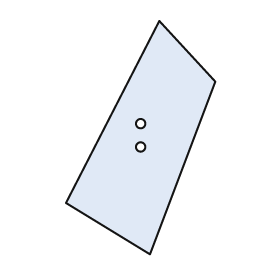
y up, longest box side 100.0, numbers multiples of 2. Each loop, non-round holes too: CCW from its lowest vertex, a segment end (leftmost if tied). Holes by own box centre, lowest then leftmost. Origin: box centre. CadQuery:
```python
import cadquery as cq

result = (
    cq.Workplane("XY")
    .moveTo(4.0, -50.0)
    .lineTo(32.0, 24.0)
    .lineTo(8.0, 50.0)
    .lineTo(-32.0, -28.0)
    .close()
    .moveTo(0.0, -4.0)
    .circle(2.0)
    .moveTo(0.0, 6.0)
    .circle(2.0)
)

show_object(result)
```